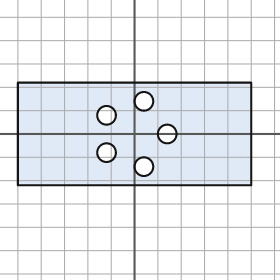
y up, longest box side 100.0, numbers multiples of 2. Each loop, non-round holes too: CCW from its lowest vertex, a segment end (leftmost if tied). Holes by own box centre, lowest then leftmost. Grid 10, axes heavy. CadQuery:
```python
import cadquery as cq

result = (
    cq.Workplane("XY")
    .moveTo(-50.0, -22.0)
    .lineTo(50.0, -22.0)
    .lineTo(50.0, 22.0)
    .lineTo(-50.0, 22.0)
    .close()
    .moveTo(4.0, -14.0)
    .circle(4.0)
    .moveTo(-12.0, -8.0)
    .circle(4.0)
    .moveTo(14.0, 0.0)
    .circle(4.0)
    .moveTo(-12.0, 8.0)
    .circle(4.0)
    .moveTo(4.0, 14.0)
    .circle(4.0)
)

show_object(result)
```